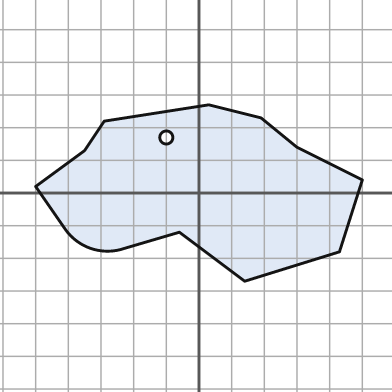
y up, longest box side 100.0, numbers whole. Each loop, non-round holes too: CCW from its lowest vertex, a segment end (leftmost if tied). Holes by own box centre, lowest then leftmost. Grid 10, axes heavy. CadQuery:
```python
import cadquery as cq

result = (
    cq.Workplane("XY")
    .moveTo(14.0, -27.0)
    .lineTo(43.0, -18.0)
    .lineTo(50.0, 4.0)
    .lineTo(30.0, 14.0)
    .lineTo(19.0, 23.0)
    .lineTo(3.0, 27.0)
    .lineTo(-29.0, 22.0)
    .lineTo(-35.0, 13.0)
    .lineTo(-50.0, 2.0)
    .lineTo(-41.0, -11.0)
    .threePointArc((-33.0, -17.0), (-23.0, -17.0))
    .lineTo(-6.0, -12.0)
    .close()
    .moveTo(-10.0, 17.0)
    .circle(2.0)
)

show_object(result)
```